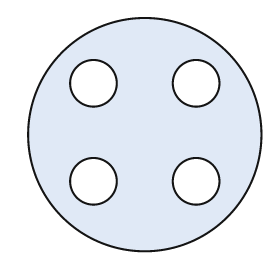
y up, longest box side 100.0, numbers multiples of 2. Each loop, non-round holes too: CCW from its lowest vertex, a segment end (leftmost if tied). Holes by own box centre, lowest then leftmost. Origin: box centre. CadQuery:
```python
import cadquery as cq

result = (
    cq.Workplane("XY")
    .moveTo(0.0, 0.0)
    .circle(50.0)
    .moveTo(-22.0, -20.0)
    .circle(10.0)
    .moveTo(22.0, -20.0)
    .circle(10.0)
    .moveTo(-22.0, 22.0)
    .circle(10.0)
    .moveTo(22.0, 22.0)
    .circle(10.0)
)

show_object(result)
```